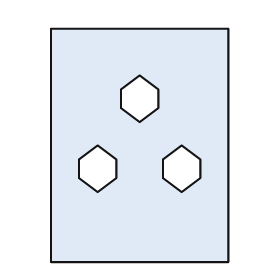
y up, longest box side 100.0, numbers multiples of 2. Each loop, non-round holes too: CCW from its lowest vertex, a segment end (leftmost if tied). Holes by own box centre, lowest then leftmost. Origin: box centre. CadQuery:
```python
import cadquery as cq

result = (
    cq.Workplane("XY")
    .moveTo(-38.0, -50.0)
    .lineTo(38.0, -50.0)
    .lineTo(38.0, 50.0)
    .lineTo(-38.0, 50.0)
    .close()
    .moveTo(-18.0, -20.0)
    .lineTo(-10.0, -14.0)
    .lineTo(-10.0, -6.0)
    .lineTo(-18.0, 0.0)
    .lineTo(-26.0, -6.0)
    .lineTo(-26.0, -14.0)
    .close()
    .moveTo(18.0, -20.0)
    .lineTo(26.0, -14.0)
    .lineTo(26.0, -6.0)
    .lineTo(18.0, 0.0)
    .lineTo(10.0, -6.0)
    .lineTo(10.0, -14.0)
    .close()
    .moveTo(0.0, 10.0)
    .lineTo(8.0, 16.0)
    .lineTo(8.0, 24.0)
    .lineTo(0.0, 30.0)
    .lineTo(-8.0, 24.0)
    .lineTo(-8.0, 16.0)
    .close()
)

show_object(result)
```